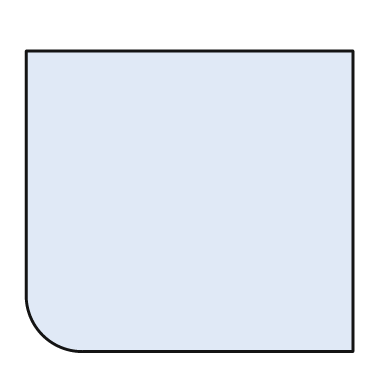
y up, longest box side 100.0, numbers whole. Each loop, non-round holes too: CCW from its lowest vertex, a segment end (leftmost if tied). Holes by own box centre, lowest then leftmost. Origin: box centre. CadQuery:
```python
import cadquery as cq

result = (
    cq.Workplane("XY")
    .moveTo(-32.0, -46.0)
    .lineTo(50.0, -46.0)
    .lineTo(50.0, 46.0)
    .lineTo(-50.0, 46.0)
    .lineTo(-50.0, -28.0)
    .threePointArc((-45.0, -41.0), (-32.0, -46.0))
    .close()
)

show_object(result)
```